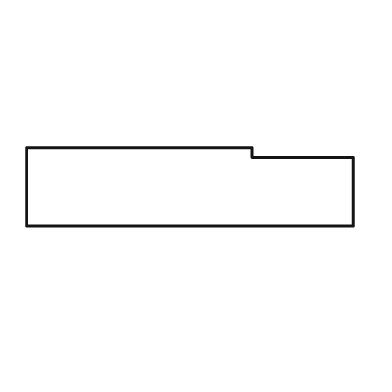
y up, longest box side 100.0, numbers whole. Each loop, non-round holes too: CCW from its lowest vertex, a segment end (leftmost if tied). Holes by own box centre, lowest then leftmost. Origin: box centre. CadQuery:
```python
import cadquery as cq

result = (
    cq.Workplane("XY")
    .moveTo(-50.0, -12.0)
    .lineTo(50.0, -12.0)
    .lineTo(50.0, 9.0)
    .lineTo(19.0, 9.0)
    .lineTo(19.0, 12.0)
    .lineTo(-50.0, 12.0)
    .close()
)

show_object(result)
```